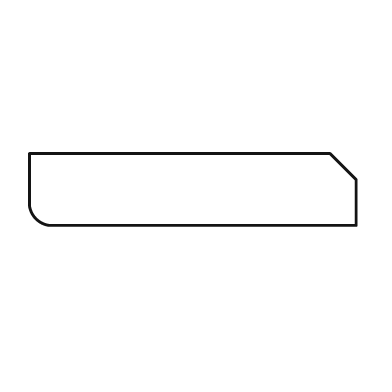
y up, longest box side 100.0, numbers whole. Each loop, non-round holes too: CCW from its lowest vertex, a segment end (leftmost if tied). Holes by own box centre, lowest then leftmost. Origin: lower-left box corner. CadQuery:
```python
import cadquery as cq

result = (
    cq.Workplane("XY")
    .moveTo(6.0, 0.0)
    .lineTo(100.0, 0.0)
    .lineTo(100.0, 14.0)
    .lineTo(92.0, 22.0)
    .lineTo(0.0, 22.0)
    .lineTo(0.0, 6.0)
    .threePointArc((2.0, 2.0), (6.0, 0.0))
    .close()
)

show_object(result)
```